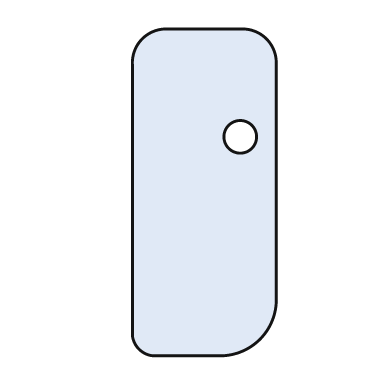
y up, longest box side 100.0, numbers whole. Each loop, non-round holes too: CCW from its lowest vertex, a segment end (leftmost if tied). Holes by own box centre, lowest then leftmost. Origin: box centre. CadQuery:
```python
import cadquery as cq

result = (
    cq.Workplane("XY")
    .moveTo(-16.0, -50.0)
    .lineTo(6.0, -50.0)
    .threePointArc((17.0, -45.0), (22.0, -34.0))
    .lineTo(22.0, 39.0)
    .threePointArc((19.0, 47.0), (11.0, 50.0))
    .lineTo(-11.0, 50.0)
    .threePointArc((-19.0, 47.0), (-22.0, 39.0))
    .lineTo(-22.0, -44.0)
    .threePointArc((-20.0, -48.0), (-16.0, -50.0))
    .close()
    .moveTo(11.0, 17.0)
    .circle(5.0)
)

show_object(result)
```